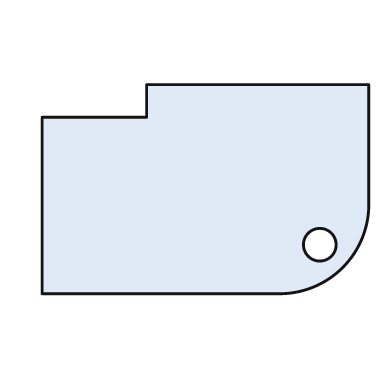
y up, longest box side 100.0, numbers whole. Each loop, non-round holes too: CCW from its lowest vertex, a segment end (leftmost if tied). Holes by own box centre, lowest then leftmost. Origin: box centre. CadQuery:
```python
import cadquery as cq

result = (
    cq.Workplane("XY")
    .moveTo(-50.0, -32.0)
    .lineTo(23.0, -32.0)
    .threePointArc((42.0, -24.0), (50.0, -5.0))
    .lineTo(50.0, 32.0)
    .lineTo(-18.0, 32.0)
    .lineTo(-18.0, 22.0)
    .lineTo(-50.0, 22.0)
    .close()
    .moveTo(35.0, -17.0)
    .circle(5.0)
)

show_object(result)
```